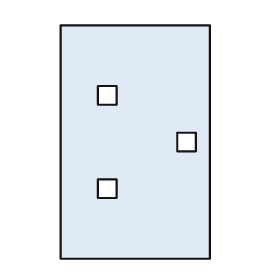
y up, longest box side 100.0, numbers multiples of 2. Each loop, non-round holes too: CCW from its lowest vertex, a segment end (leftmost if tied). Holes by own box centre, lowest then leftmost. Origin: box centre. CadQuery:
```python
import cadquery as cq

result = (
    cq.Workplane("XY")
    .moveTo(-32.0, -50.0)
    .lineTo(32.0, -50.0)
    .lineTo(32.0, 50.0)
    .lineTo(-32.0, 50.0)
    .close()
    .moveTo(-16.0, -24.0)
    .lineTo(-8.0, -24.0)
    .lineTo(-8.0, -16.0)
    .lineTo(-16.0, -16.0)
    .close()
    .moveTo(18.0, -4.0)
    .lineTo(26.0, -4.0)
    .lineTo(26.0, 4.0)
    .lineTo(18.0, 4.0)
    .close()
    .moveTo(-16.0, 16.0)
    .lineTo(-8.0, 16.0)
    .lineTo(-8.0, 24.0)
    .lineTo(-16.0, 24.0)
    .close()
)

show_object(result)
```